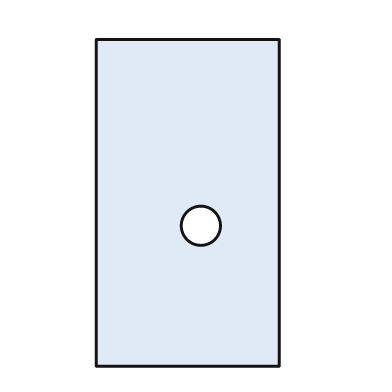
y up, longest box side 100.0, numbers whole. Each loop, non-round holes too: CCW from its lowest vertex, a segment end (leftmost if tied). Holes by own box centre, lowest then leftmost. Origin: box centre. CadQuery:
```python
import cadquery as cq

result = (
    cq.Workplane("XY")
    .moveTo(-28.0, -50.0)
    .lineTo(28.0, -50.0)
    .lineTo(28.0, 50.0)
    .lineTo(-28.0, 50.0)
    .close()
    .moveTo(4.0, -7.0)
    .circle(6.0)
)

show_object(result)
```